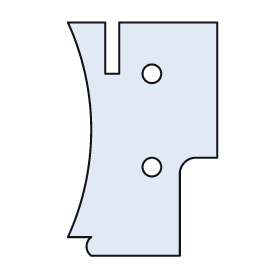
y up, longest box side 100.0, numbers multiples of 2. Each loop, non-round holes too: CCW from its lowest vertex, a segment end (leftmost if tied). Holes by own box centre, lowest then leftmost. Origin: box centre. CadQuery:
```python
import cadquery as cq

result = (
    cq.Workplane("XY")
    .moveTo(-22.0, -50.0)
    .lineTo(16.0, -50.0)
    .lineTo(16.0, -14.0)
    .threePointArc((18.0, -10.0), (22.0, -8.0))
    .lineTo(32.0, -8.0)
    .lineTo(32.0, 50.0)
    .lineTo(-10.0, 50.0)
    .lineTo(-10.0, 28.0)
    .lineTo(-16.0, 28.0)
    .lineTo(-16.0, 50.0)
    .lineTo(-32.0, 50.0)
    .threePointArc((-22.0, 4.0), (-32.0, -42.0))
    .lineTo(-22.0, -42.0)
    .threePointArc((-24.0, -46.0), (-22.0, -50.0))
    .close()
    .moveTo(4.0, -12.0)
    .circle(4.0)
    .moveTo(4.0, 28.0)
    .circle(4.0)
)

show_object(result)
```